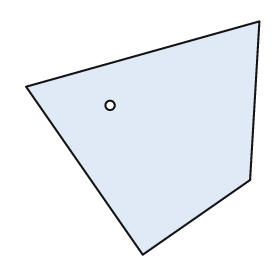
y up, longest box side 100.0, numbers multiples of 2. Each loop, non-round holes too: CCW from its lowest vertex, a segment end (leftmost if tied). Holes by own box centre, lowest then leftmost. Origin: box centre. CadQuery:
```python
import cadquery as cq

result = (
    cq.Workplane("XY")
    .moveTo(0.0, -50.0)
    .lineTo(46.0, -18.0)
    .lineTo(50.0, 50.0)
    .lineTo(-50.0, 22.0)
    .close()
    .moveTo(-14.0, 14.0)
    .circle(2.0)
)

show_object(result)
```